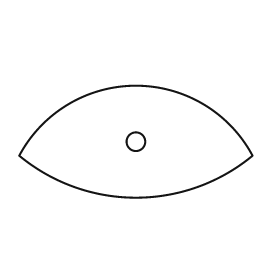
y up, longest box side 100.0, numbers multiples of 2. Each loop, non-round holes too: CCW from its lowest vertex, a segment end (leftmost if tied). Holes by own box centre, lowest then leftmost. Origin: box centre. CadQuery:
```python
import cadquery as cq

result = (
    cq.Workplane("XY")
    .moveTo(-50.0, -6.0)
    .threePointArc((0.0, -24.0), (50.0, -6.0))
    .threePointArc((0.0, 24.0), (-50.0, -6.0))
    .close()
    .moveTo(0.0, 0.0)
    .circle(4.0)
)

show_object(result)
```